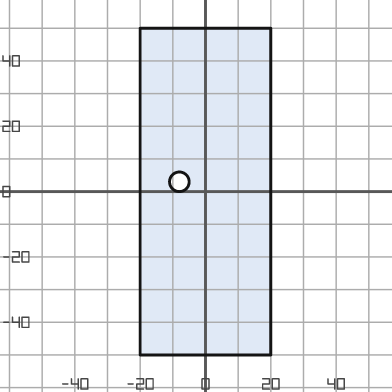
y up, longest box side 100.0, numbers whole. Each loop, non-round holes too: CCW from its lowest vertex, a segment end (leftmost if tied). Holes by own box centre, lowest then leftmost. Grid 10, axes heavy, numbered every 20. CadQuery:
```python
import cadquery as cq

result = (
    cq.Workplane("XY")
    .moveTo(-20.0, -50.0)
    .lineTo(20.0, -50.0)
    .lineTo(20.0, 50.0)
    .lineTo(-20.0, 50.0)
    .close()
    .moveTo(-8.0, 3.0)
    .circle(3.0)
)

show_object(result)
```